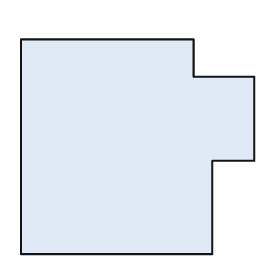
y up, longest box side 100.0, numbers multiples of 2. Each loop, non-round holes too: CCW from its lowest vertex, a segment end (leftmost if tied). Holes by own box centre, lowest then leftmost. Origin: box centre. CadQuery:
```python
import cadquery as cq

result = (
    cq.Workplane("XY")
    .moveTo(-50.0, -46.0)
    .lineTo(32.0, -46.0)
    .lineTo(32.0, -6.0)
    .lineTo(50.0, -6.0)
    .lineTo(50.0, 30.0)
    .lineTo(24.0, 30.0)
    .lineTo(24.0, 46.0)
    .lineTo(-50.0, 46.0)
    .close()
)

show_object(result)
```